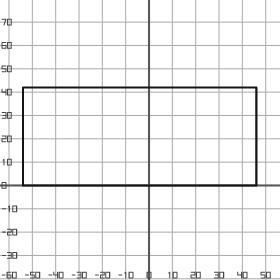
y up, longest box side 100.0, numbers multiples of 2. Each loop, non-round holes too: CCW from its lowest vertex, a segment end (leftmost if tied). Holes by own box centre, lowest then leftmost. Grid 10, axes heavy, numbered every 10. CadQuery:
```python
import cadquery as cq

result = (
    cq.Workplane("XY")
    .moveTo(-54.0, 0.0)
    .lineTo(46.0, 0.0)
    .lineTo(46.0, 42.0)
    .lineTo(-54.0, 42.0)
    .close()
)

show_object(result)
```